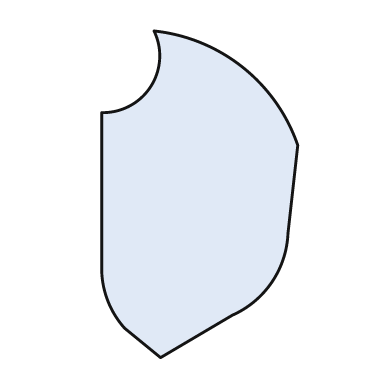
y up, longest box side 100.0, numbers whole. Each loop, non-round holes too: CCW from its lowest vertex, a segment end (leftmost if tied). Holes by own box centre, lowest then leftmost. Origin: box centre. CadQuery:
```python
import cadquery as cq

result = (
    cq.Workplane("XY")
    .moveTo(-12.0, -50.0)
    .lineTo(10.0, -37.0)
    .threePointArc((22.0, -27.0), (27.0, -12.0))
    .lineTo(30.0, 15.0)
    .threePointArc((13.0, 39.0), (-14.0, 50.0))
    .threePointArc((-15.0, 33.0), (-30.0, 25.0))
    .lineTo(-30.0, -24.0)
    .threePointArc((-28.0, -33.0), (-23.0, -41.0))
    .close()
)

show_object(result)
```